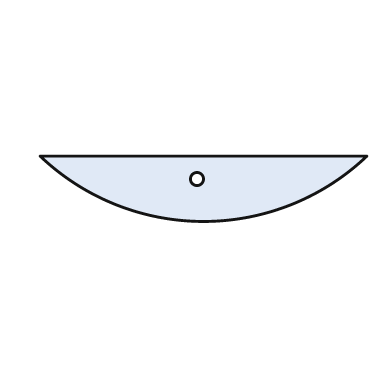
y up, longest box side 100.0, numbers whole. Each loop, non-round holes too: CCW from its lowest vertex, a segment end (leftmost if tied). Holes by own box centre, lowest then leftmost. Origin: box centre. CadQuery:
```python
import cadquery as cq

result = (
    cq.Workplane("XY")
    .moveTo(-50.0, 10.0)
    .threePointArc((0.0, -10.0), (50.0, 10.0))
    .close()
    .moveTo(-2.0, 3.0)
    .circle(2.0)
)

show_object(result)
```